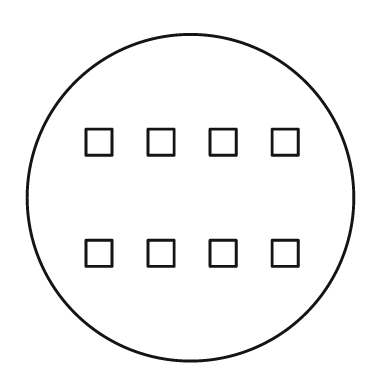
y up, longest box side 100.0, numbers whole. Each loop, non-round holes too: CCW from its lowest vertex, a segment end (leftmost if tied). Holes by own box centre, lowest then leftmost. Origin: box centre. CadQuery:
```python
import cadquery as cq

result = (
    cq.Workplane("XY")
    .moveTo(0.0, 0.0)
    .circle(50.0)
    .moveTo(-32.0, -21.0)
    .lineTo(-24.0, -21.0)
    .lineTo(-24.0, -13.0)
    .lineTo(-32.0, -13.0)
    .close()
    .moveTo(-13.0, -21.0)
    .lineTo(-5.0, -21.0)
    .lineTo(-5.0, -13.0)
    .lineTo(-13.0, -13.0)
    .close()
    .moveTo(6.0, -21.0)
    .lineTo(14.0, -21.0)
    .lineTo(14.0, -13.0)
    .lineTo(6.0, -13.0)
    .close()
    .moveTo(25.0, -21.0)
    .lineTo(33.0, -21.0)
    .lineTo(33.0, -13.0)
    .lineTo(25.0, -13.0)
    .close()
    .moveTo(-32.0, 13.0)
    .lineTo(-24.0, 13.0)
    .lineTo(-24.0, 21.0)
    .lineTo(-32.0, 21.0)
    .close()
    .moveTo(-13.0, 13.0)
    .lineTo(-5.0, 13.0)
    .lineTo(-5.0, 21.0)
    .lineTo(-13.0, 21.0)
    .close()
    .moveTo(6.0, 13.0)
    .lineTo(14.0, 13.0)
    .lineTo(14.0, 21.0)
    .lineTo(6.0, 21.0)
    .close()
    .moveTo(25.0, 13.0)
    .lineTo(33.0, 13.0)
    .lineTo(33.0, 21.0)
    .lineTo(25.0, 21.0)
    .close()
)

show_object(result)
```